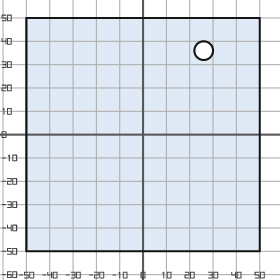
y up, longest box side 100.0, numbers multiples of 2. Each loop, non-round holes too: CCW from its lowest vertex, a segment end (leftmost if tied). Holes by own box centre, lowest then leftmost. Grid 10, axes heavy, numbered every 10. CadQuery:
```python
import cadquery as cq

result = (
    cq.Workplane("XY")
    .moveTo(-50.0, -50.0)
    .lineTo(50.0, -50.0)
    .lineTo(50.0, 50.0)
    .lineTo(-50.0, 50.0)
    .close()
    .moveTo(26.0, 36.0)
    .circle(4.0)
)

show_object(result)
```